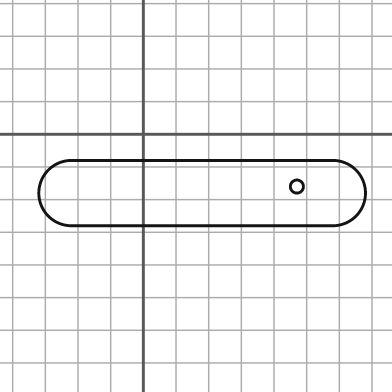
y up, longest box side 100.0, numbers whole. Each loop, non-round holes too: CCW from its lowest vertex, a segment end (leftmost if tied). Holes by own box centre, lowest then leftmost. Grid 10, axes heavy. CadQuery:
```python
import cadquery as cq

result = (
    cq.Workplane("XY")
    .moveTo(-22.0, -28.0)
    .lineTo(58.0, -28.0)
    .threePointArc((68.0, -18.0), (58.0, -8.0))
    .lineTo(-22.0, -8.0)
    .threePointArc((-32.0, -18.0), (-22.0, -28.0))
    .close()
    .moveTo(47.0, -16.0)
    .circle(2.0)
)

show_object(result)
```